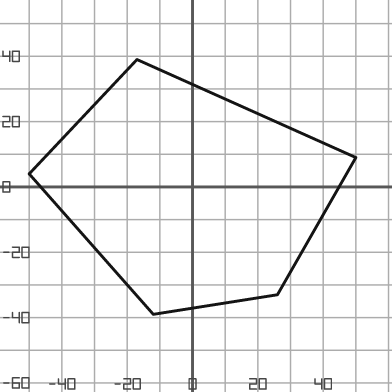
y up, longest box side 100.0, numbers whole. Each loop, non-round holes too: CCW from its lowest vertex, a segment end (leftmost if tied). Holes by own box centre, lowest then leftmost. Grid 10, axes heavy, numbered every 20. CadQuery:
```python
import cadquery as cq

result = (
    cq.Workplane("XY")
    .moveTo(-12.0, -39.0)
    .lineTo(26.0, -33.0)
    .lineTo(50.0, 9.0)
    .lineTo(-17.0, 39.0)
    .lineTo(-50.0, 4.0)
    .close()
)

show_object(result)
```